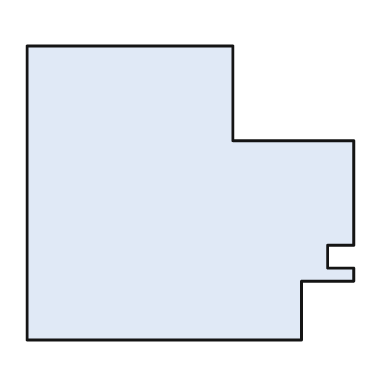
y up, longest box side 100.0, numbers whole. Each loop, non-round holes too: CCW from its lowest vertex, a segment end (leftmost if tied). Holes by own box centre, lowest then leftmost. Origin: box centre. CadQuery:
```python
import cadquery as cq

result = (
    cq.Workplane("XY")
    .moveTo(-50.0, -45.0)
    .lineTo(34.0, -45.0)
    .lineTo(34.0, -27.0)
    .lineTo(50.0, -27.0)
    .lineTo(50.0, -23.0)
    .lineTo(42.0, -23.0)
    .lineTo(42.0, -16.0)
    .lineTo(50.0, -16.0)
    .lineTo(50.0, 16.0)
    .lineTo(13.0, 16.0)
    .lineTo(13.0, 45.0)
    .lineTo(-50.0, 45.0)
    .close()
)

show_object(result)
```